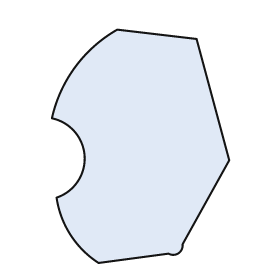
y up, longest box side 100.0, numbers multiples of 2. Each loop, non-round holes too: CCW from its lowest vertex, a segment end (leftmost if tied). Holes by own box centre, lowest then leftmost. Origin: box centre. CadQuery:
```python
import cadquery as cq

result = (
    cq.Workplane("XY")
    .moveTo(-18.0, -50.0)
    .lineTo(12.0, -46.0)
    .threePointArc((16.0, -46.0), (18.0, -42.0))
    .lineTo(38.0, -6.0)
    .lineTo(24.0, 46.0)
    .lineTo(-10.0, 50.0)
    .threePointArc((-28.0, 34.0), (-38.0, 12.0))
    .threePointArc((-24.0, -4.0), (-36.0, -22.0))
    .threePointArc((-30.0, -38.0), (-18.0, -50.0))
    .close()
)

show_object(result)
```